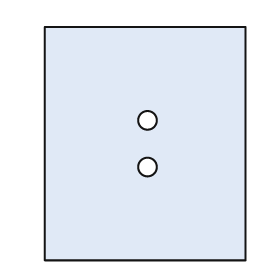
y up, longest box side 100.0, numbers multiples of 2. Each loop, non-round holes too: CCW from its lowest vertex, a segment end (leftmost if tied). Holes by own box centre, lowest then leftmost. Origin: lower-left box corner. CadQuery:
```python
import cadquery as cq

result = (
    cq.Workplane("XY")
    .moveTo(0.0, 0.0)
    .lineTo(86.0, 0.0)
    .lineTo(86.0, 100.0)
    .lineTo(0.0, 100.0)
    .close()
    .moveTo(44.0, 40.0)
    .circle(4.0)
    .moveTo(44.0, 60.0)
    .circle(4.0)
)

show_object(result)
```